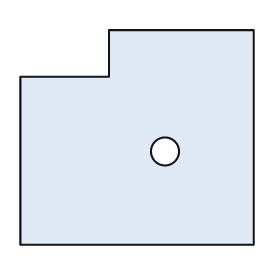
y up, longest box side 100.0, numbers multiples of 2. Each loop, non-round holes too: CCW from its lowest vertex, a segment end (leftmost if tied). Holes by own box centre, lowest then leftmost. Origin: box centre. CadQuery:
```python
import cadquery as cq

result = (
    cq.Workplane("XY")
    .moveTo(-50.0, -46.0)
    .lineTo(50.0, -46.0)
    .lineTo(50.0, 46.0)
    .lineTo(-12.0, 46.0)
    .lineTo(-12.0, 26.0)
    .lineTo(-50.0, 26.0)
    .close()
    .moveTo(12.0, -6.0)
    .circle(6.0)
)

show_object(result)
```